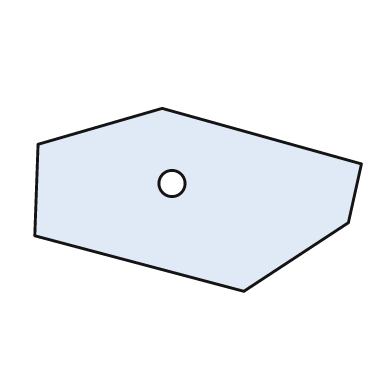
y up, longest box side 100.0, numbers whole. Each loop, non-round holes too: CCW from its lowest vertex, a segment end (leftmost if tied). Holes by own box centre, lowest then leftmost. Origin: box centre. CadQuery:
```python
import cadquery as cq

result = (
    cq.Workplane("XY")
    .moveTo(14.0, -28.0)
    .lineTo(46.0, -7.0)
    .lineTo(50.0, 11.0)
    .lineTo(-11.0, 28.0)
    .lineTo(-49.0, 17.0)
    .lineTo(-50.0, -11.0)
    .close()
    .moveTo(-8.0, 5.0)
    .circle(4.0)
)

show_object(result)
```